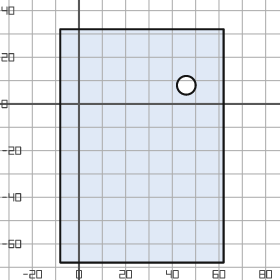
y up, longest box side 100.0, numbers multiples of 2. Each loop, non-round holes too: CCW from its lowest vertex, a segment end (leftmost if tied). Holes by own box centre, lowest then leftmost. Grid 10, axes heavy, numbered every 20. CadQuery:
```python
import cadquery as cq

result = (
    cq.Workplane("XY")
    .moveTo(-8.0, -68.0)
    .lineTo(62.0, -68.0)
    .lineTo(62.0, 32.0)
    .lineTo(-8.0, 32.0)
    .close()
    .moveTo(46.0, 8.0)
    .circle(4.0)
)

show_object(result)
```